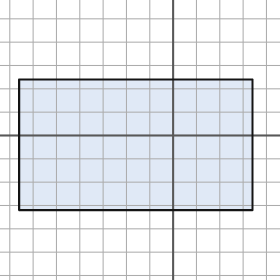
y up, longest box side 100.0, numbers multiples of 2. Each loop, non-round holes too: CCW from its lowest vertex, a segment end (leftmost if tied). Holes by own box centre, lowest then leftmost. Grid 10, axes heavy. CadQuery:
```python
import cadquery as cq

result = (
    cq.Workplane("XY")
    .moveTo(-66.0, -32.0)
    .lineTo(34.0, -32.0)
    .lineTo(34.0, 24.0)
    .lineTo(-66.0, 24.0)
    .close()
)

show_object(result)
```